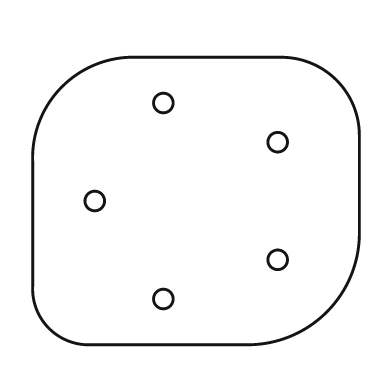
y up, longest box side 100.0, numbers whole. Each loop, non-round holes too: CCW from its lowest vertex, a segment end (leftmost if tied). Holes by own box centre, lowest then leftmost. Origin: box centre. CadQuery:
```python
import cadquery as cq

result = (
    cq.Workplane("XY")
    .moveTo(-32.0, -44.0)
    .lineTo(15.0, -44.0)
    .threePointArc((40.0, -34.0), (50.0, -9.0))
    .lineTo(50.0, 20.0)
    .threePointArc((43.0, 37.0), (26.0, 44.0))
    .lineTo(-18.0, 44.0)
    .threePointArc((-41.0, 35.0), (-50.0, 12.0))
    .lineTo(-50.0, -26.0)
    .threePointArc((-45.0, -39.0), (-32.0, -44.0))
    .close()
    .moveTo(-10.0, -30.0)
    .circle(3.0)
    .moveTo(25.0, -18.0)
    .circle(3.0)
    .moveTo(-31.0, 0.0)
    .circle(3.0)
    .moveTo(25.0, 18.0)
    .circle(3.0)
    .moveTo(-10.0, 30.0)
    .circle(3.0)
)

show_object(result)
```